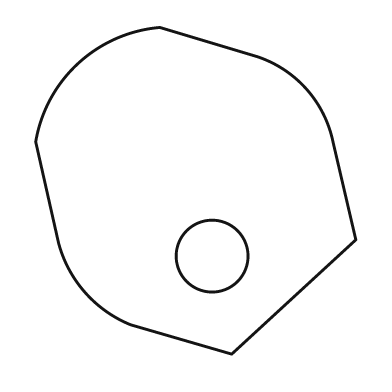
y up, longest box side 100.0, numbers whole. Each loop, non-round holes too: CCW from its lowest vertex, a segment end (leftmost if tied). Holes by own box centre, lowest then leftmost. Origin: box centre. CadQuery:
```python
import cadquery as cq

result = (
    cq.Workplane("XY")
    .moveTo(11.0, -50.0)
    .lineTo(49.0, -15.0)
    .lineTo(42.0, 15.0)
    .threePointArc((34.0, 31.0), (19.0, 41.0))
    .lineTo(-11.0, 50.0)
    .threePointArc((-36.0, 39.0), (-49.0, 15.0))
    .lineTo(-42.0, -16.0)
    .threePointArc((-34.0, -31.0), (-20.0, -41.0))
    .close()
    .moveTo(5.0, -20.0)
    .circle(11.0)
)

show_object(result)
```